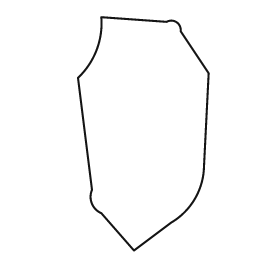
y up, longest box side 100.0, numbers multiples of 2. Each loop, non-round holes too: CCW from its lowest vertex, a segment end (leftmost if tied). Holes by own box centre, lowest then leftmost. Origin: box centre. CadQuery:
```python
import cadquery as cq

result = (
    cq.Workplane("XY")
    .moveTo(-4.0, -50.0)
    .lineTo(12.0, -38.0)
    .threePointArc((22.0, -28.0), (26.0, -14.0))
    .lineTo(28.0, 26.0)
    .lineTo(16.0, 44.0)
    .threePointArc((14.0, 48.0), (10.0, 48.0))
    .lineTo(-18.0, 50.0)
    .threePointArc((-20.0, 36.0), (-28.0, 24.0))
    .lineTo(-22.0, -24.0)
    .threePointArc((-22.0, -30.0), (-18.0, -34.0))
    .close()
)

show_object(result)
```